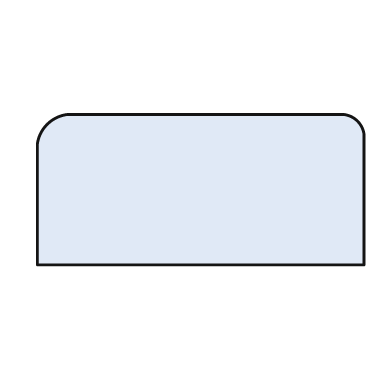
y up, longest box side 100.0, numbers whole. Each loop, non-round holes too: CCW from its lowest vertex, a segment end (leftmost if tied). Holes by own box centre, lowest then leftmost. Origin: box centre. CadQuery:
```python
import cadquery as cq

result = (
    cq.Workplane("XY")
    .moveTo(-50.0, -23.0)
    .lineTo(50.0, -23.0)
    .lineTo(50.0, 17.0)
    .threePointArc((48.0, 21.0), (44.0, 23.0))
    .lineTo(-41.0, 23.0)
    .threePointArc((-47.0, 20.0), (-50.0, 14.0))
    .close()
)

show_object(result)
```